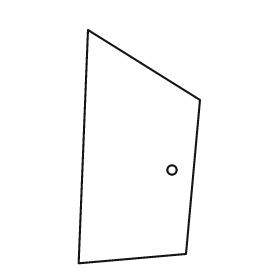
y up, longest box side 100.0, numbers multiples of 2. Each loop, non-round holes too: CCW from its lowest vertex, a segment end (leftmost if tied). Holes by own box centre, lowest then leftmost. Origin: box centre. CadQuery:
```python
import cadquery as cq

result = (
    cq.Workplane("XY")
    .moveTo(-26.0, -50.0)
    .lineTo(20.0, -46.0)
    .lineTo(26.0, 20.0)
    .lineTo(-22.0, 50.0)
    .close()
    .moveTo(14.0, -10.0)
    .circle(2.0)
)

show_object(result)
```